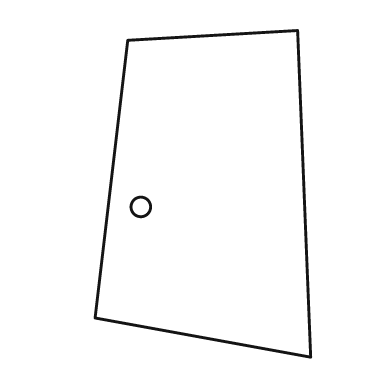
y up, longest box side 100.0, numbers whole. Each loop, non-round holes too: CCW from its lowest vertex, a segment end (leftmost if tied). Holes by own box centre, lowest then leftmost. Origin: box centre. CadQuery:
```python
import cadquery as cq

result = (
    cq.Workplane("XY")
    .moveTo(33.0, -50.0)
    .lineTo(29.0, 50.0)
    .lineTo(-23.0, 47.0)
    .lineTo(-33.0, -38.0)
    .close()
    .moveTo(-19.0, -4.0)
    .circle(3.0)
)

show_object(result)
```